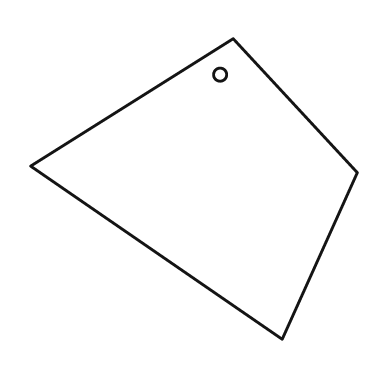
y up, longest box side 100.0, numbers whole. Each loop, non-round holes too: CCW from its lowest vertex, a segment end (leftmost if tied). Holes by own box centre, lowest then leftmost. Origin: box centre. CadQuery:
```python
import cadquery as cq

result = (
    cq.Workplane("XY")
    .moveTo(27.0, -46.0)
    .lineTo(50.0, 5.0)
    .lineTo(12.0, 46.0)
    .lineTo(-50.0, 7.0)
    .close()
    .moveTo(8.0, 35.0)
    .circle(2.0)
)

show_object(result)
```